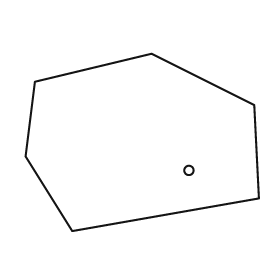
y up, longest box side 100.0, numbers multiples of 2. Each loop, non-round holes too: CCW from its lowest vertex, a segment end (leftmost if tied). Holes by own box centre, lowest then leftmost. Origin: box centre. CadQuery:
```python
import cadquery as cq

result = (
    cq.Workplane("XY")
    .moveTo(-30.0, -38.0)
    .lineTo(50.0, -24.0)
    .lineTo(48.0, 16.0)
    .lineTo(4.0, 38.0)
    .lineTo(-46.0, 26.0)
    .lineTo(-50.0, -6.0)
    .close()
    .moveTo(20.0, -12.0)
    .circle(2.0)
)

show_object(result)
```